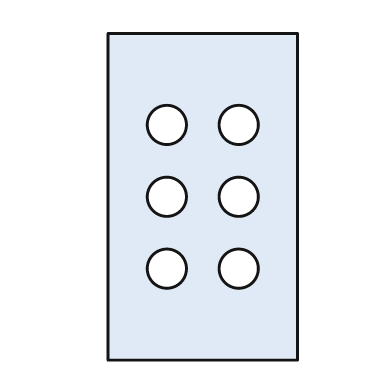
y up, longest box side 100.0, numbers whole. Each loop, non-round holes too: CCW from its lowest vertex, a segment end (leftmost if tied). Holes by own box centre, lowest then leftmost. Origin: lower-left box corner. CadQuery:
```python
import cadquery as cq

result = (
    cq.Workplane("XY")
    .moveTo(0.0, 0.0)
    .lineTo(58.0, 0.0)
    .lineTo(58.0, 100.0)
    .lineTo(0.0, 100.0)
    .close()
    .moveTo(18.0, 28.0)
    .circle(6.0)
    .moveTo(40.0, 28.0)
    .circle(6.0)
    .moveTo(18.0, 50.0)
    .circle(6.0)
    .moveTo(40.0, 50.0)
    .circle(6.0)
    .moveTo(18.0, 72.0)
    .circle(6.0)
    .moveTo(40.0, 72.0)
    .circle(6.0)
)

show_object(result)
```